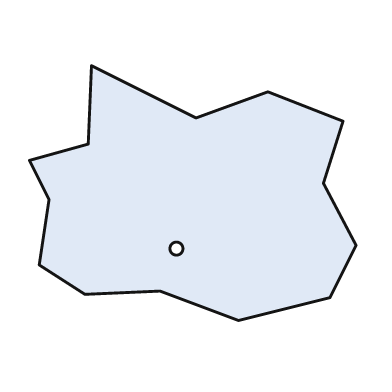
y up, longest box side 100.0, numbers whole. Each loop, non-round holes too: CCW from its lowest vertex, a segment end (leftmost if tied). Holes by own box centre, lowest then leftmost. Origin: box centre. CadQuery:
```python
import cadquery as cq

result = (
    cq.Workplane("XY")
    .moveTo(14.0, -39.0)
    .lineTo(42.0, -32.0)
    .lineTo(50.0, -16.0)
    .lineTo(40.0, 3.0)
    .lineTo(46.0, 22.0)
    .lineTo(23.0, 31.0)
    .lineTo(1.0, 23.0)
    .lineTo(-31.0, 39.0)
    .lineTo(-32.0, 15.0)
    .lineTo(-50.0, 10.0)
    .lineTo(-44.0, -2.0)
    .lineTo(-47.0, -22.0)
    .lineTo(-33.0, -31.0)
    .lineTo(-10.0, -30.0)
    .close()
    .moveTo(-5.0, -17.0)
    .circle(2.0)
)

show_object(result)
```